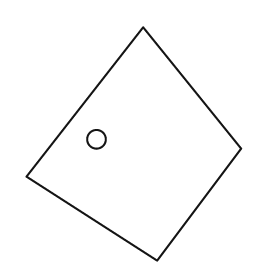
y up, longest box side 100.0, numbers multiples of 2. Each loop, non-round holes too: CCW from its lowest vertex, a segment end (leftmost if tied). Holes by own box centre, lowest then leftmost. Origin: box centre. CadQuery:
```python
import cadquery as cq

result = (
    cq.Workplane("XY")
    .moveTo(10.0, -50.0)
    .lineTo(46.0, -2.0)
    .lineTo(4.0, 50.0)
    .lineTo(-46.0, -14.0)
    .close()
    .moveTo(-16.0, 2.0)
    .circle(4.0)
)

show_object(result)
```